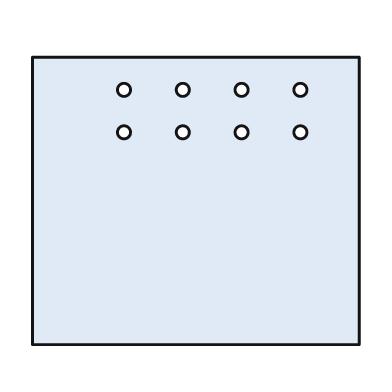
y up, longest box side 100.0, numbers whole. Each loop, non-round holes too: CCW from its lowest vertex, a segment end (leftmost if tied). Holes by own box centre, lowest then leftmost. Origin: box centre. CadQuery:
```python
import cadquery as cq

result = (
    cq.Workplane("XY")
    .moveTo(-50.0, -44.0)
    .lineTo(50.0, -44.0)
    .lineTo(50.0, 44.0)
    .lineTo(-50.0, 44.0)
    .close()
    .moveTo(-22.0, 21.0)
    .circle(2.0)
    .moveTo(-4.0, 21.0)
    .circle(2.0)
    .moveTo(14.0, 21.0)
    .circle(2.0)
    .moveTo(32.0, 21.0)
    .circle(2.0)
    .moveTo(-22.0, 34.0)
    .circle(2.0)
    .moveTo(-4.0, 34.0)
    .circle(2.0)
    .moveTo(14.0, 34.0)
    .circle(2.0)
    .moveTo(32.0, 34.0)
    .circle(2.0)
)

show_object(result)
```